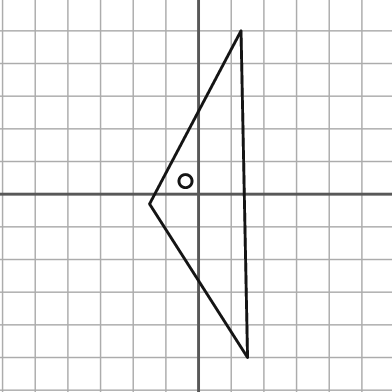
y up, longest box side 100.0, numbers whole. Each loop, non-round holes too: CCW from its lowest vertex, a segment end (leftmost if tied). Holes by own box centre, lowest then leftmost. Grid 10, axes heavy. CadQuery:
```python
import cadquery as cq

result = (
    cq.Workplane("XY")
    .moveTo(15.0, -50.0)
    .lineTo(13.0, 50.0)
    .lineTo(-15.0, -3.0)
    .close()
    .moveTo(-4.0, 4.0)
    .circle(2.0)
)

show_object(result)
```